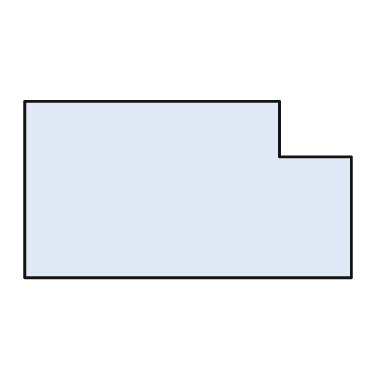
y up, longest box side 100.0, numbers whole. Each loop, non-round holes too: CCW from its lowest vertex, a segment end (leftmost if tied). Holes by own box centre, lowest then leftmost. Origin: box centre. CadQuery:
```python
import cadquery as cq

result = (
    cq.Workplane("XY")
    .moveTo(-50.0, -27.0)
    .lineTo(50.0, -27.0)
    .lineTo(50.0, 10.0)
    .lineTo(28.0, 10.0)
    .lineTo(28.0, 27.0)
    .lineTo(-50.0, 27.0)
    .close()
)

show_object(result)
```